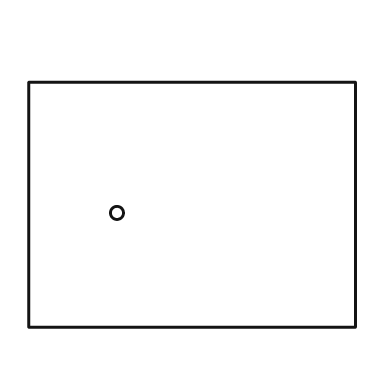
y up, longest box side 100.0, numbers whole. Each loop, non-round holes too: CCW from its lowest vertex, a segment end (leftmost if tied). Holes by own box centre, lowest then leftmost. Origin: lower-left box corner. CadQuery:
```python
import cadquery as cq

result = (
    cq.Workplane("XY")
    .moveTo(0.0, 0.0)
    .lineTo(100.0, 0.0)
    .lineTo(100.0, 75.0)
    .lineTo(0.0, 75.0)
    .close()
    .moveTo(27.0, 35.0)
    .circle(2.0)
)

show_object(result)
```